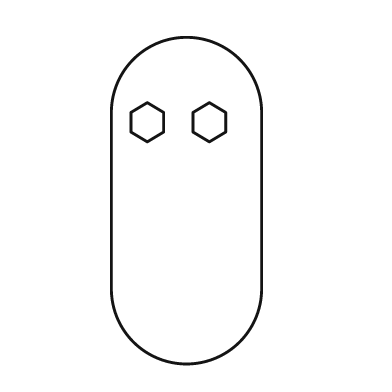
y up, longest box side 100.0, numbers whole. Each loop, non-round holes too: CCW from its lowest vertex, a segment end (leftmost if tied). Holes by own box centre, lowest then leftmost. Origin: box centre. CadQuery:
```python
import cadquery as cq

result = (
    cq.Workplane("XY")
    .moveTo(-23.0, -27.0)
    .threePointArc((0.0, -50.0), (23.0, -27.0))
    .lineTo(23.0, 27.0)
    .threePointArc((0.0, 50.0), (-23.0, 27.0))
    .close()
    .moveTo(-12.0, 18.0)
    .lineTo(-7.0, 21.0)
    .lineTo(-7.0, 27.0)
    .lineTo(-12.0, 30.0)
    .lineTo(-17.0, 27.0)
    .lineTo(-17.0, 21.0)
    .close()
    .moveTo(7.0, 18.0)
    .lineTo(12.0, 21.0)
    .lineTo(12.0, 27.0)
    .lineTo(7.0, 30.0)
    .lineTo(2.0, 27.0)
    .lineTo(2.0, 21.0)
    .close()
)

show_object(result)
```